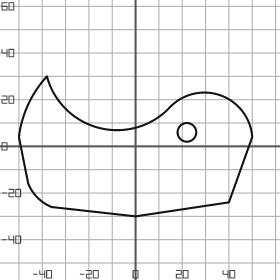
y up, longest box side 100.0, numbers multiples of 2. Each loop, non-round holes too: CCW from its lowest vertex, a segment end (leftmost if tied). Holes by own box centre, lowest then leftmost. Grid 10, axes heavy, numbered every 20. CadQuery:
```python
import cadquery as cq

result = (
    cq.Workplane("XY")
    .moveTo(0.0, -30.0)
    .lineTo(40.0, -24.0)
    .lineTo(50.0, 4.0)
    .threePointArc((36.0, 22.0), (14.0, 16.0))
    .threePointArc((-16.0, 8.0), (-38.0, 30.0))
    .threePointArc((-46.0, 18.0), (-50.0, 4.0))
    .lineTo(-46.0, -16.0)
    .threePointArc((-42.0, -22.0), (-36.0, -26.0))
    .close()
    .moveTo(22.0, 6.0)
    .circle(4.0)
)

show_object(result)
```